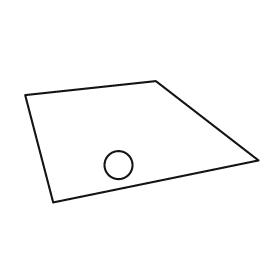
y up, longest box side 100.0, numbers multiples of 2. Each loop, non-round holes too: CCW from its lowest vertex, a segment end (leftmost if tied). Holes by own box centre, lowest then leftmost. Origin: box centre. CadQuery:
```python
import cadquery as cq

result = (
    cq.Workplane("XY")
    .moveTo(-38.0, -26.0)
    .lineTo(50.0, -8.0)
    .lineTo(6.0, 26.0)
    .lineTo(-50.0, 20.0)
    .close()
    .moveTo(-10.0, -10.0)
    .circle(6.0)
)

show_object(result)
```